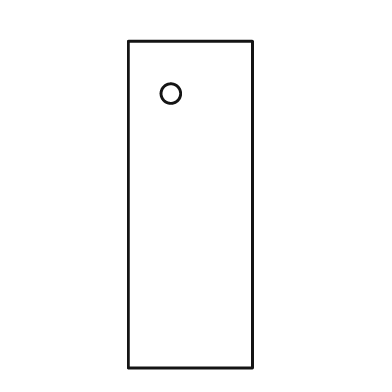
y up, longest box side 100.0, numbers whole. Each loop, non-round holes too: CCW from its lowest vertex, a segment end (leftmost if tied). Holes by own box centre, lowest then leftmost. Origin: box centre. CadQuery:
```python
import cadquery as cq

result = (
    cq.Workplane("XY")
    .moveTo(-19.0, -50.0)
    .lineTo(19.0, -50.0)
    .lineTo(19.0, 50.0)
    .lineTo(-19.0, 50.0)
    .close()
    .moveTo(-6.0, 34.0)
    .circle(3.0)
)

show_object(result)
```